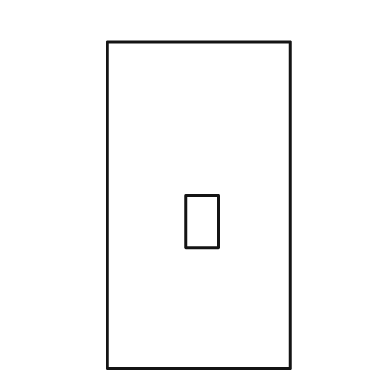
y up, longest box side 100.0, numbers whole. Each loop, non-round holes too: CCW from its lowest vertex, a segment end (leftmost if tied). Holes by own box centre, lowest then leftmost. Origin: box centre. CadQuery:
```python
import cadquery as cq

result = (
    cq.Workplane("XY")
    .moveTo(-28.0, -50.0)
    .lineTo(28.0, -50.0)
    .lineTo(28.0, 50.0)
    .lineTo(-28.0, 50.0)
    .close()
    .moveTo(-4.0, -13.0)
    .lineTo(6.0, -13.0)
    .lineTo(6.0, 3.0)
    .lineTo(-4.0, 3.0)
    .close()
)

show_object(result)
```